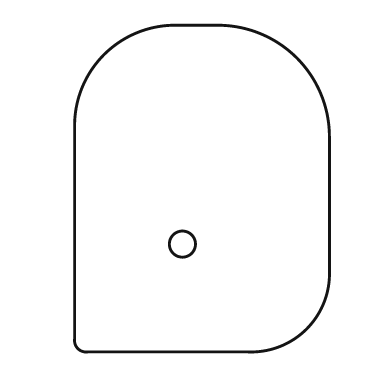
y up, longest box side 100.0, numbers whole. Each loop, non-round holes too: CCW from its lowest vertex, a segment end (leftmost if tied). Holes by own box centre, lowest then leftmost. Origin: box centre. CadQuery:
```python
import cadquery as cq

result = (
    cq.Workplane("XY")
    .moveTo(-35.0, -50.0)
    .lineTo(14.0, -50.0)
    .threePointArc((32.0, -43.0), (39.0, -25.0))
    .lineTo(39.0, 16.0)
    .threePointArc((29.0, 40.0), (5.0, 50.0))
    .lineTo(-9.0, 50.0)
    .threePointArc((-30.0, 41.0), (-39.0, 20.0))
    .lineTo(-39.0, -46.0)
    .threePointArc((-38.0, -49.0), (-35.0, -50.0))
    .close()
    .moveTo(-6.0, -17.0)
    .circle(4.0)
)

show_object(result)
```